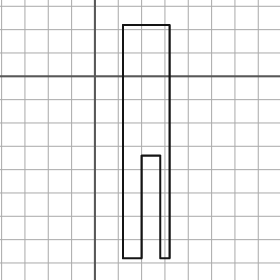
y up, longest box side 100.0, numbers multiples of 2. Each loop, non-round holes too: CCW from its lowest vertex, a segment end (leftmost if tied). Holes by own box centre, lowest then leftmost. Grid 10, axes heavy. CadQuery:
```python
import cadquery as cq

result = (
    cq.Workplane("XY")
    .moveTo(12.0, -78.0)
    .lineTo(20.0, -78.0)
    .lineTo(20.0, -34.0)
    .lineTo(28.0, -34.0)
    .lineTo(28.0, -78.0)
    .lineTo(32.0, -78.0)
    .lineTo(32.0, 22.0)
    .lineTo(12.0, 22.0)
    .close()
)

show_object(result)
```